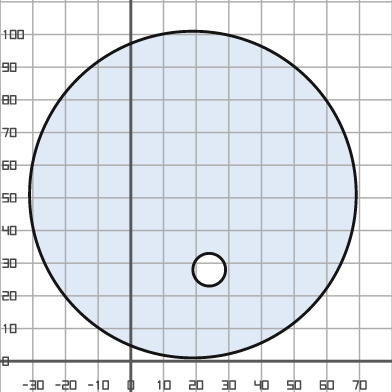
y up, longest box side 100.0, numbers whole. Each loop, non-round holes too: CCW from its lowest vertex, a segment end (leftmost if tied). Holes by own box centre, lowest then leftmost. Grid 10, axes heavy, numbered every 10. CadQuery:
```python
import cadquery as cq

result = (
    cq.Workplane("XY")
    .moveTo(19.0, 51.0)
    .circle(50.0)
    .moveTo(24.0, 28.0)
    .circle(5.0)
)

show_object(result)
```